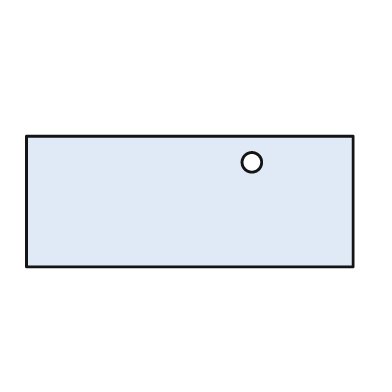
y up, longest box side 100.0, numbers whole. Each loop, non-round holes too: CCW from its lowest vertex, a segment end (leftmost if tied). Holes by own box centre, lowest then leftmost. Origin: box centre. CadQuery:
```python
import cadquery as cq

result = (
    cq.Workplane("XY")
    .moveTo(-50.0, -20.0)
    .lineTo(50.0, -20.0)
    .lineTo(50.0, 20.0)
    .lineTo(-50.0, 20.0)
    .close()
    .moveTo(19.0, 12.0)
    .circle(3.0)
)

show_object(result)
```